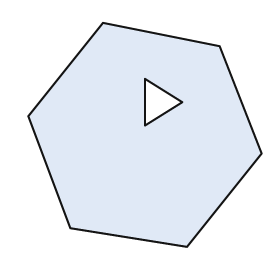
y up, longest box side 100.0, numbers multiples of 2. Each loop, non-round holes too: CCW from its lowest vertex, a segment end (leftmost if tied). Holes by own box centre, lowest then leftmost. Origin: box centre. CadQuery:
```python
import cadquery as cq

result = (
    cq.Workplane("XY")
    .moveTo(18.0, -48.0)
    .lineTo(50.0, -8.0)
    .lineTo(32.0, 38.0)
    .lineTo(-18.0, 48.0)
    .lineTo(-50.0, 8.0)
    .lineTo(-32.0, -40.0)
    .close()
    .moveTo(0.0, 4.0)
    .lineTo(16.0, 14.0)
    .lineTo(0.0, 24.0)
    .close()
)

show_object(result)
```